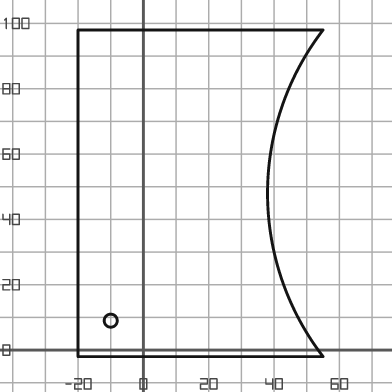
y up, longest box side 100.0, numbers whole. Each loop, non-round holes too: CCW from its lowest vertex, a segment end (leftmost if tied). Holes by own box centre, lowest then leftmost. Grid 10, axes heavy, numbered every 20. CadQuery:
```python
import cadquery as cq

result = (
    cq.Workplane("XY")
    .moveTo(-20.0, -2.0)
    .lineTo(55.0, -2.0)
    .threePointArc((38.0, 48.0), (55.0, 98.0))
    .lineTo(-20.0, 98.0)
    .close()
    .moveTo(-10.0, 9.0)
    .circle(2.0)
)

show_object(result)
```